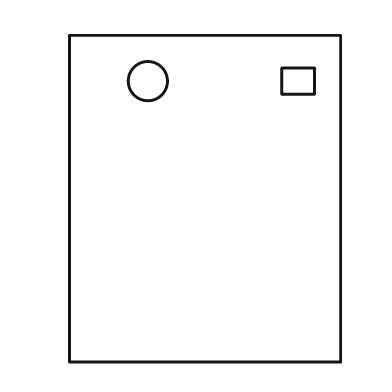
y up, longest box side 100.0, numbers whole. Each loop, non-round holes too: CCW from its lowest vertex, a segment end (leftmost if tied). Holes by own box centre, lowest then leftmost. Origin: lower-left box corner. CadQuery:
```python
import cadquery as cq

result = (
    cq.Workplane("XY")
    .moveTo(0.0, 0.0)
    .lineTo(83.0, 0.0)
    .lineTo(83.0, 100.0)
    .lineTo(0.0, 100.0)
    .close()
    .moveTo(24.0, 86.0)
    .circle(6.0)
    .moveTo(65.0, 82.0)
    .lineTo(75.0, 82.0)
    .lineTo(75.0, 90.0)
    .lineTo(65.0, 90.0)
    .close()
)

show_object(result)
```